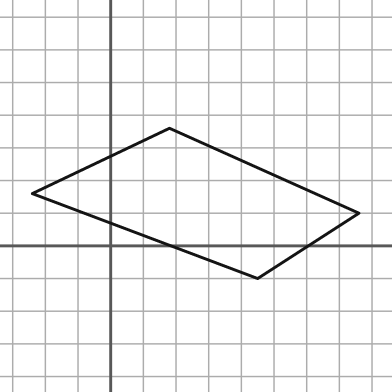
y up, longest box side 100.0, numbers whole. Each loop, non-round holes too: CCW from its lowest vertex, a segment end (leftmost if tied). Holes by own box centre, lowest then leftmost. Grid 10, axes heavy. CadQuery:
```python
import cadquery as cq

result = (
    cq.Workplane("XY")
    .moveTo(45.0, -10.0)
    .lineTo(76.0, 10.0)
    .lineTo(18.0, 36.0)
    .lineTo(-24.0, 16.0)
    .close()
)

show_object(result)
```